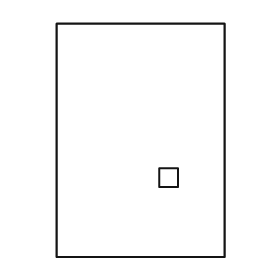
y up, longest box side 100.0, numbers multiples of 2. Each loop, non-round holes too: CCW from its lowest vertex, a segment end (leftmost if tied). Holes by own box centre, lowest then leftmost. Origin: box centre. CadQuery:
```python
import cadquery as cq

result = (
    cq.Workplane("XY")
    .moveTo(-36.0, -50.0)
    .lineTo(36.0, -50.0)
    .lineTo(36.0, 50.0)
    .lineTo(-36.0, 50.0)
    .close()
    .moveTo(8.0, -20.0)
    .lineTo(16.0, -20.0)
    .lineTo(16.0, -12.0)
    .lineTo(8.0, -12.0)
    .close()
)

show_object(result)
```